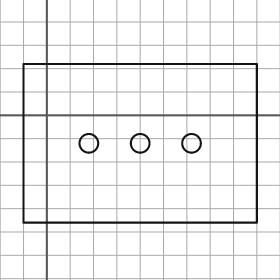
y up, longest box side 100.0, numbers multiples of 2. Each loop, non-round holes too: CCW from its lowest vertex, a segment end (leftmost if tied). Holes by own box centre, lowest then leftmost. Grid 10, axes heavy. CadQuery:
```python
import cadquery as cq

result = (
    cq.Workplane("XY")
    .moveTo(-10.0, -46.0)
    .lineTo(90.0, -46.0)
    .lineTo(90.0, 22.0)
    .lineTo(-10.0, 22.0)
    .close()
    .moveTo(18.0, -12.0)
    .circle(4.0)
    .moveTo(40.0, -12.0)
    .circle(4.0)
    .moveTo(62.0, -12.0)
    .circle(4.0)
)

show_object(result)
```